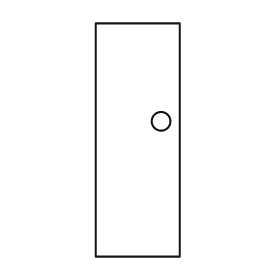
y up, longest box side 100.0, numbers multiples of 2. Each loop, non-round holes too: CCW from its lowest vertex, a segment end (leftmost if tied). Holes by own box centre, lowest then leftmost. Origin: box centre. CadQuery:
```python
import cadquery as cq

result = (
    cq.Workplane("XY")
    .moveTo(-18.0, -50.0)
    .lineTo(18.0, -50.0)
    .lineTo(18.0, 50.0)
    .lineTo(-18.0, 50.0)
    .close()
    .moveTo(10.0, 8.0)
    .circle(4.0)
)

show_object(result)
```